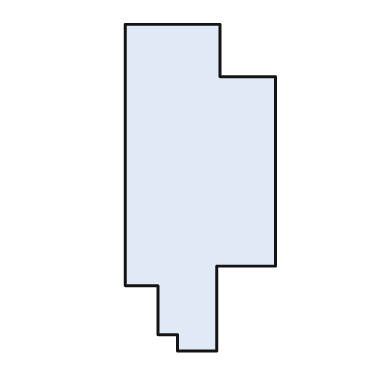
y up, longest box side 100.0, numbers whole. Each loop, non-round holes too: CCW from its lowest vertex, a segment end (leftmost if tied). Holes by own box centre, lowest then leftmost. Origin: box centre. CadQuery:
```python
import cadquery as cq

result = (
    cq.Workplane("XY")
    .moveTo(-7.0, -50.0)
    .lineTo(5.0, -50.0)
    .lineTo(5.0, -24.0)
    .lineTo(23.0, -24.0)
    .lineTo(23.0, 34.0)
    .lineTo(6.0, 34.0)
    .lineTo(6.0, 50.0)
    .lineTo(-23.0, 50.0)
    .lineTo(-23.0, -30.0)
    .lineTo(-13.0, -30.0)
    .lineTo(-13.0, -45.0)
    .lineTo(-7.0, -45.0)
    .close()
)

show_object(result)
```